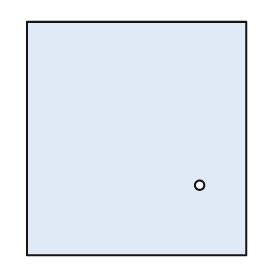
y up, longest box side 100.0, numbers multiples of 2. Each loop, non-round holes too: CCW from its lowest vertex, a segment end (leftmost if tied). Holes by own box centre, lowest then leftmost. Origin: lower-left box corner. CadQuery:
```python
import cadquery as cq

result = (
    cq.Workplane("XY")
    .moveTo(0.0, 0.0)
    .lineTo(94.0, 0.0)
    .lineTo(94.0, 100.0)
    .lineTo(0.0, 100.0)
    .close()
    .moveTo(74.0, 30.0)
    .circle(2.0)
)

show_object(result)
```